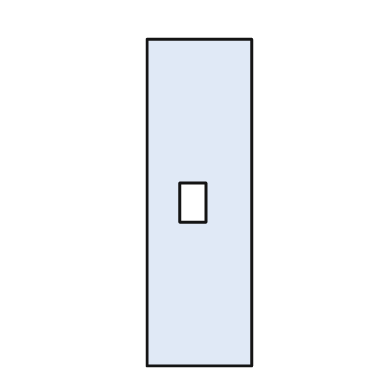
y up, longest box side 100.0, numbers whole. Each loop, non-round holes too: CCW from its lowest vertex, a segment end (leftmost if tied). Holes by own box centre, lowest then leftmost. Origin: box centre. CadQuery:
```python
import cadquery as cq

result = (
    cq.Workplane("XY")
    .moveTo(-16.0, -50.0)
    .lineTo(16.0, -50.0)
    .lineTo(16.0, 50.0)
    .lineTo(-16.0, 50.0)
    .close()
    .moveTo(-6.0, -6.0)
    .lineTo(2.0, -6.0)
    .lineTo(2.0, 6.0)
    .lineTo(-6.0, 6.0)
    .close()
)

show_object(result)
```